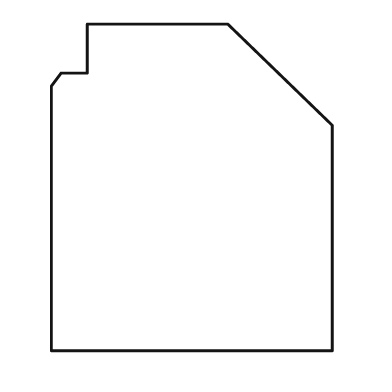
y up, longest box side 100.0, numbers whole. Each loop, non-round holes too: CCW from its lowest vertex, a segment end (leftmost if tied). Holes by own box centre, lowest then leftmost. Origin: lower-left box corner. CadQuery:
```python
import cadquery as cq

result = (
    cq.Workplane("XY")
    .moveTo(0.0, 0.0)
    .lineTo(86.0, 0.0)
    .lineTo(86.0, 69.0)
    .lineTo(54.0, 100.0)
    .lineTo(11.0, 100.0)
    .lineTo(11.0, 85.0)
    .lineTo(3.0, 85.0)
    .lineTo(0.0, 81.0)
    .close()
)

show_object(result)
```